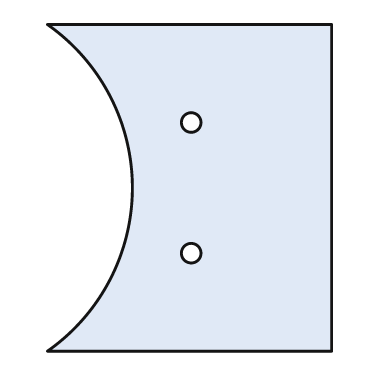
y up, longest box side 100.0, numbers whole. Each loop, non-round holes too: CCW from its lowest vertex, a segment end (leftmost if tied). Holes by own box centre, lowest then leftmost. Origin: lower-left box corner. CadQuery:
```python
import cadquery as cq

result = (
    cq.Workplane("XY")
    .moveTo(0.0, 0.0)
    .lineTo(87.0, 0.0)
    .lineTo(87.0, 100.0)
    .lineTo(0.0, 100.0)
    .threePointArc((26.0, 50.0), (0.0, 0.0))
    .close()
    .moveTo(44.0, 30.0)
    .circle(3.0)
    .moveTo(44.0, 70.0)
    .circle(3.0)
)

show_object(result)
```